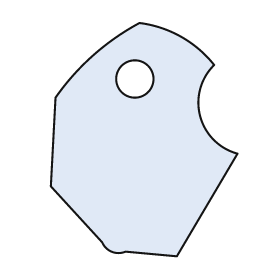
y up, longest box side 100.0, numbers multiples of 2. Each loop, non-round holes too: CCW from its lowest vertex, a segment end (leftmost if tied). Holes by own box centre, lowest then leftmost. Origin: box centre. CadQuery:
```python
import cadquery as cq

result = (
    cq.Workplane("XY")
    .moveTo(14.0, -50.0)
    .lineTo(40.0, -6.0)
    .threePointArc((24.0, 10.0), (30.0, 32.0))
    .threePointArc((16.0, 44.0), (-2.0, 50.0))
    .threePointArc((-22.0, 36.0), (-38.0, 18.0))
    .lineTo(-40.0, -20.0)
    .lineTo(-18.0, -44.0)
    .threePointArc((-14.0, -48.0), (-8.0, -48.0))
    .close()
    .moveTo(-4.0, 26.0)
    .circle(8.0)
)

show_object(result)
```